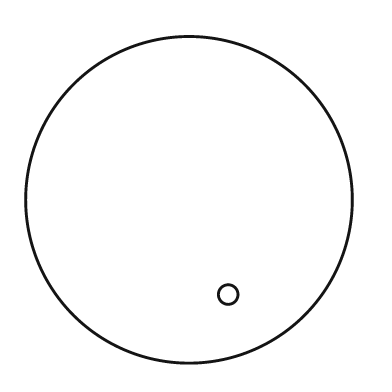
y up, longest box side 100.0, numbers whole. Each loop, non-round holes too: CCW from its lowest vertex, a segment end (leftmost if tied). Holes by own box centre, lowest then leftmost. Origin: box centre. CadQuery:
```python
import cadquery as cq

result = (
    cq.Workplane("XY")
    .moveTo(0.0, 0.0)
    .circle(50.0)
    .moveTo(12.0, -29.0)
    .circle(3.0)
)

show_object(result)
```